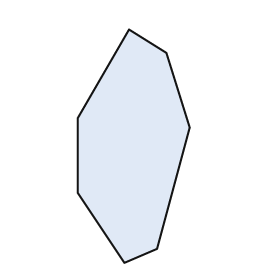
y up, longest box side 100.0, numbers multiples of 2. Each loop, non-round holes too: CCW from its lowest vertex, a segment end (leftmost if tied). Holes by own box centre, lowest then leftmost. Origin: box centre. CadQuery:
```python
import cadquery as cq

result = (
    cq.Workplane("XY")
    .moveTo(-4.0, -50.0)
    .lineTo(10.0, -44.0)
    .lineTo(24.0, 8.0)
    .lineTo(14.0, 40.0)
    .lineTo(-2.0, 50.0)
    .lineTo(-24.0, 12.0)
    .lineTo(-24.0, -20.0)
    .close()
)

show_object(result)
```